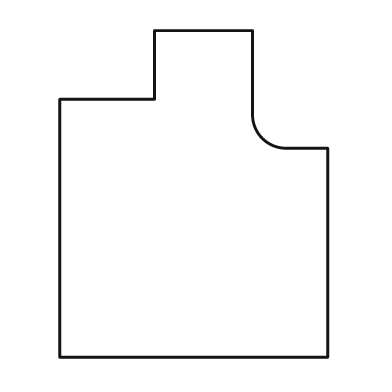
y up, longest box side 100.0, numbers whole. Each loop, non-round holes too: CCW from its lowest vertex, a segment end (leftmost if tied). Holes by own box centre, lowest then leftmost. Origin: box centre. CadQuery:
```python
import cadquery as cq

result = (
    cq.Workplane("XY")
    .moveTo(-41.0, -50.0)
    .lineTo(41.0, -50.0)
    .lineTo(41.0, 14.0)
    .lineTo(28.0, 14.0)
    .threePointArc((21.0, 17.0), (18.0, 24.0))
    .lineTo(18.0, 50.0)
    .lineTo(-12.0, 50.0)
    .lineTo(-12.0, 29.0)
    .lineTo(-41.0, 29.0)
    .close()
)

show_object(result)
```